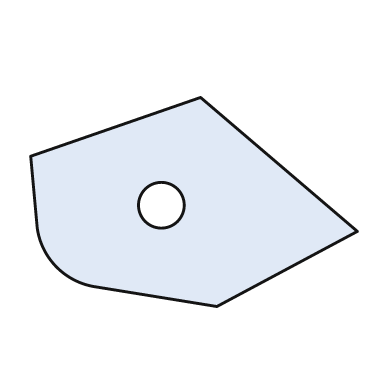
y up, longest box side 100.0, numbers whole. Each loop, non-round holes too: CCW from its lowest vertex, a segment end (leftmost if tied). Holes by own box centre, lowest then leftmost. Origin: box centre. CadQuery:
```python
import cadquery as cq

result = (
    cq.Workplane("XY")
    .moveTo(7.0, -32.0)
    .lineTo(50.0, -9.0)
    .lineTo(2.0, 32.0)
    .lineTo(-50.0, 14.0)
    .lineTo(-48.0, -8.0)
    .threePointArc((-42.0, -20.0), (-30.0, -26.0))
    .close()
    .moveTo(-10.0, -1.0)
    .circle(7.0)
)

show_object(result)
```